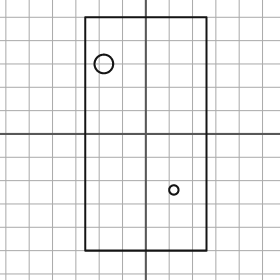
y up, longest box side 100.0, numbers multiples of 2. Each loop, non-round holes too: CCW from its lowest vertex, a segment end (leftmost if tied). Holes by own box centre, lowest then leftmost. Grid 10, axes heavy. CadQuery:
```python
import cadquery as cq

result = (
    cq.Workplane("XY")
    .moveTo(-26.0, -50.0)
    .lineTo(26.0, -50.0)
    .lineTo(26.0, 50.0)
    .lineTo(-26.0, 50.0)
    .close()
    .moveTo(12.0, -24.0)
    .circle(2.0)
    .moveTo(-18.0, 30.0)
    .circle(4.0)
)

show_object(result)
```